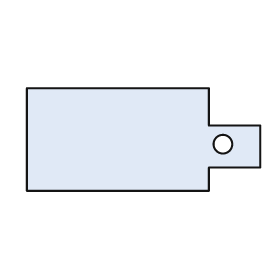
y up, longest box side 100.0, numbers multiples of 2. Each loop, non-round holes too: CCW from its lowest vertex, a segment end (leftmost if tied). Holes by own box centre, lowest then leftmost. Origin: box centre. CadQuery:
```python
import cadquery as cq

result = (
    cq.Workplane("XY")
    .moveTo(-50.0, -22.0)
    .lineTo(28.0, -22.0)
    .lineTo(28.0, -12.0)
    .lineTo(50.0, -12.0)
    .lineTo(50.0, 6.0)
    .lineTo(28.0, 6.0)
    .lineTo(28.0, 22.0)
    .lineTo(-50.0, 22.0)
    .close()
    .moveTo(34.0, -2.0)
    .circle(4.0)
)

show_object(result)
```